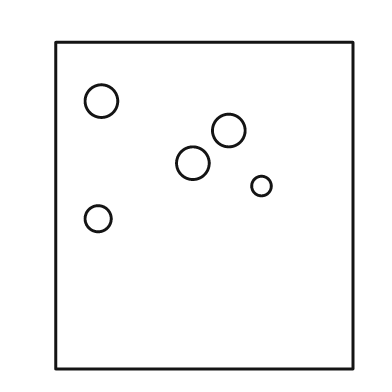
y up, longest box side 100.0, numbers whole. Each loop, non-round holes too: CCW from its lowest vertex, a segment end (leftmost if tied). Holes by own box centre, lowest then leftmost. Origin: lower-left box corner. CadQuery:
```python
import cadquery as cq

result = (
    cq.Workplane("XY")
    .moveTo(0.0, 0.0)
    .lineTo(91.0, 0.0)
    .lineTo(91.0, 100.0)
    .lineTo(0.0, 100.0)
    .close()
    .moveTo(13.0, 46.0)
    .circle(4.0)
    .moveTo(63.0, 56.0)
    .circle(3.0)
    .moveTo(42.0, 63.0)
    .circle(5.0)
    .moveTo(53.0, 73.0)
    .circle(5.0)
    .moveTo(14.0, 82.0)
    .circle(5.0)
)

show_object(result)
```